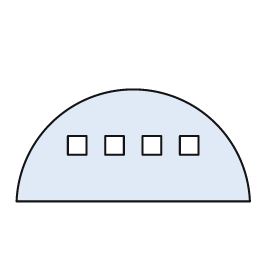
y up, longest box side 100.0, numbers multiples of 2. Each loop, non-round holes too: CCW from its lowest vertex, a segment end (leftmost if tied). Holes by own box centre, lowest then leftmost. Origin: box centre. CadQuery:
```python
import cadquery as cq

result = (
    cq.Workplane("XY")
    .moveTo(-50.0, -24.0)
    .lineTo(50.0, -24.0)
    .threePointArc((0.0, 24.0), (-50.0, -24.0))
    .close()
    .moveTo(-28.0, -4.0)
    .lineTo(-20.0, -4.0)
    .lineTo(-20.0, 4.0)
    .lineTo(-28.0, 4.0)
    .close()
    .moveTo(-12.0, -4.0)
    .lineTo(-4.0, -4.0)
    .lineTo(-4.0, 4.0)
    .lineTo(-12.0, 4.0)
    .close()
    .moveTo(4.0, -4.0)
    .lineTo(12.0, -4.0)
    .lineTo(12.0, 4.0)
    .lineTo(4.0, 4.0)
    .close()
    .moveTo(20.0, -4.0)
    .lineTo(28.0, -4.0)
    .lineTo(28.0, 4.0)
    .lineTo(20.0, 4.0)
    .close()
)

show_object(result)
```